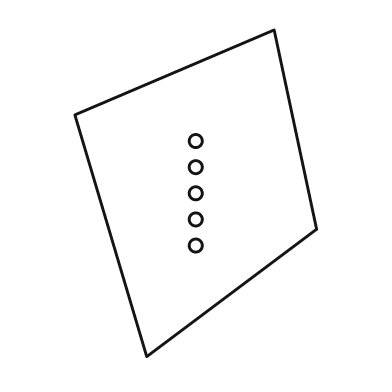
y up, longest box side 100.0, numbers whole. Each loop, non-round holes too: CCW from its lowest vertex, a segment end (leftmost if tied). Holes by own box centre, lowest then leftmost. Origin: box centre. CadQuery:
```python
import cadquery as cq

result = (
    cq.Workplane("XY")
    .moveTo(-15.0, -50.0)
    .lineTo(37.0, -11.0)
    .lineTo(24.0, 50.0)
    .lineTo(-37.0, 24.0)
    .close()
    .moveTo(0.0, -16.0)
    .circle(2.0)
    .moveTo(0.0, -8.0)
    .circle(2.0)
    .moveTo(0.0, 0.0)
    .circle(2.0)
    .moveTo(0.0, 8.0)
    .circle(2.0)
    .moveTo(0.0, 16.0)
    .circle(2.0)
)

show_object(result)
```